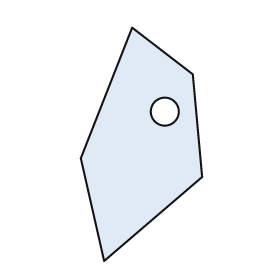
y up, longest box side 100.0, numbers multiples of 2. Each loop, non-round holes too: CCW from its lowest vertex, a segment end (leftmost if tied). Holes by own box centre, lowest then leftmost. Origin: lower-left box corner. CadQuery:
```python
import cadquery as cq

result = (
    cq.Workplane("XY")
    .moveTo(10.0, 0.0)
    .lineTo(52.0, 36.0)
    .lineTo(48.0, 80.0)
    .lineTo(22.0, 100.0)
    .lineTo(0.0, 44.0)
    .close()
    .moveTo(36.0, 64.0)
    .circle(6.0)
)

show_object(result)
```